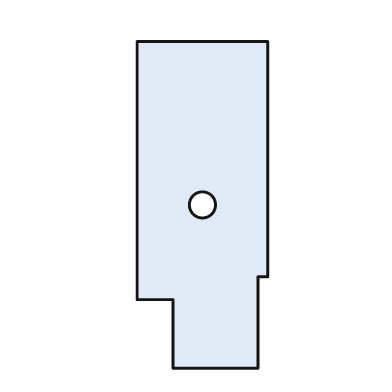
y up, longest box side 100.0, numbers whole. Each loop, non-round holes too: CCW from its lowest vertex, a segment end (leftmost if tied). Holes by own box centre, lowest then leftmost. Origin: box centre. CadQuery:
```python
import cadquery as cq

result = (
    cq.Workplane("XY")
    .moveTo(-9.0, -50.0)
    .lineTo(17.0, -50.0)
    .lineTo(17.0, -22.0)
    .lineTo(20.0, -22.0)
    .lineTo(20.0, 50.0)
    .lineTo(-20.0, 50.0)
    .lineTo(-20.0, -29.0)
    .lineTo(-9.0, -29.0)
    .close()
    .moveTo(0.0, 0.0)
    .circle(4.0)
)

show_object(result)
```